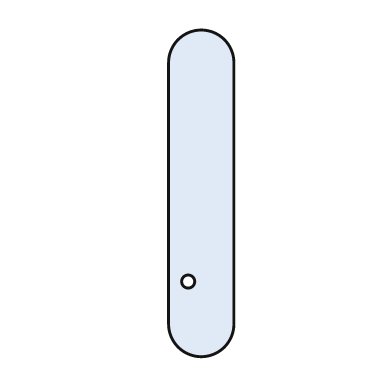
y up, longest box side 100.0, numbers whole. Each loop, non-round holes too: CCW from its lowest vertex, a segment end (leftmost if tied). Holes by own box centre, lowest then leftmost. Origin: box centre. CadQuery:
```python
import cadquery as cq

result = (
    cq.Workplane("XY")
    .moveTo(-10.0, -40.0)
    .threePointArc((0.0, -50.0), (10.0, -40.0))
    .lineTo(10.0, 40.0)
    .threePointArc((0.0, 50.0), (-10.0, 40.0))
    .close()
    .moveTo(-4.0, -27.0)
    .circle(2.0)
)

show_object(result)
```